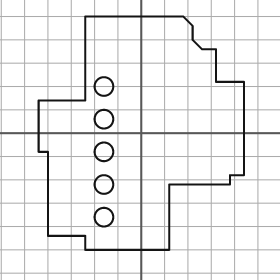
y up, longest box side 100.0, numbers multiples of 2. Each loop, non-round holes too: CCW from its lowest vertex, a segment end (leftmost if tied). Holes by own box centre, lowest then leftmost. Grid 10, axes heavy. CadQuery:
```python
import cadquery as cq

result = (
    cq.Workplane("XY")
    .moveTo(-24.0, -50.0)
    .lineTo(12.0, -50.0)
    .lineTo(12.0, -22.0)
    .lineTo(38.0, -22.0)
    .lineTo(38.0, -18.0)
    .lineTo(44.0, -18.0)
    .lineTo(44.0, 22.0)
    .lineTo(32.0, 22.0)
    .lineTo(32.0, 36.0)
    .lineTo(26.0, 36.0)
    .lineTo(22.0, 40.0)
    .lineTo(22.0, 46.0)
    .lineTo(18.0, 50.0)
    .lineTo(-24.0, 50.0)
    .lineTo(-24.0, 14.0)
    .lineTo(-44.0, 14.0)
    .lineTo(-44.0, -8.0)
    .lineTo(-40.0, -8.0)
    .lineTo(-40.0, -44.0)
    .lineTo(-24.0, -44.0)
    .close()
    .moveTo(-16.0, -36.0)
    .circle(4.0)
    .moveTo(-16.0, -22.0)
    .circle(4.0)
    .moveTo(-16.0, -8.0)
    .circle(4.0)
    .moveTo(-16.0, 6.0)
    .circle(4.0)
    .moveTo(-16.0, 20.0)
    .circle(4.0)
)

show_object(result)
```